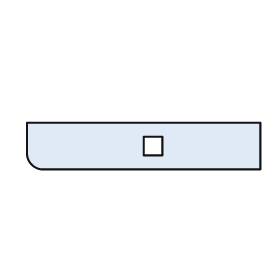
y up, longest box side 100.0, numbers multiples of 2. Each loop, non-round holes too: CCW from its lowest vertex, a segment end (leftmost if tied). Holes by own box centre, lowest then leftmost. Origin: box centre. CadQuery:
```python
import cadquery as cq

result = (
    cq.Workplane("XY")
    .moveTo(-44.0, -10.0)
    .lineTo(50.0, -10.0)
    .lineTo(50.0, 10.0)
    .lineTo(-50.0, 10.0)
    .lineTo(-50.0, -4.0)
    .threePointArc((-48.0, -8.0), (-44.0, -10.0))
    .close()
    .moveTo(0.0, -4.0)
    .lineTo(8.0, -4.0)
    .lineTo(8.0, 4.0)
    .lineTo(0.0, 4.0)
    .close()
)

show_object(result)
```